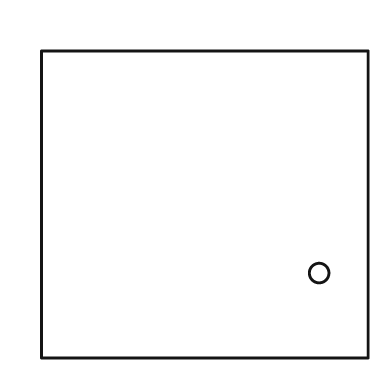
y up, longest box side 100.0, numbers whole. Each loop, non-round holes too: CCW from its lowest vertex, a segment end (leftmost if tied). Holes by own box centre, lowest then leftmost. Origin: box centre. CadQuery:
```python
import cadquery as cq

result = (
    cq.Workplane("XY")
    .moveTo(-50.0, -47.0)
    .lineTo(50.0, -47.0)
    .lineTo(50.0, 47.0)
    .lineTo(-50.0, 47.0)
    .close()
    .moveTo(35.0, -21.0)
    .circle(3.0)
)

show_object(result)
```